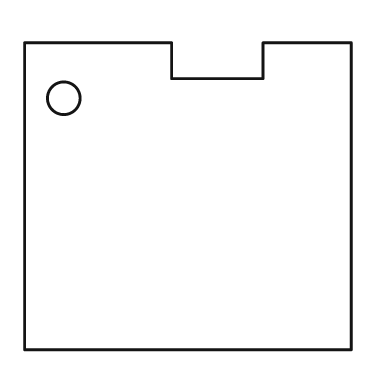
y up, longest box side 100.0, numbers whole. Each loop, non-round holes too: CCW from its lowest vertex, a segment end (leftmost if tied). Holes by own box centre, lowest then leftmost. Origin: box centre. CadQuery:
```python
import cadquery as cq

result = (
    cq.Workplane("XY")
    .moveTo(-50.0, -47.0)
    .lineTo(50.0, -47.0)
    .lineTo(50.0, 47.0)
    .lineTo(23.0, 47.0)
    .lineTo(23.0, 36.0)
    .lineTo(-5.0, 36.0)
    .lineTo(-5.0, 47.0)
    .lineTo(-50.0, 47.0)
    .close()
    .moveTo(-38.0, 30.0)
    .circle(5.0)
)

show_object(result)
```